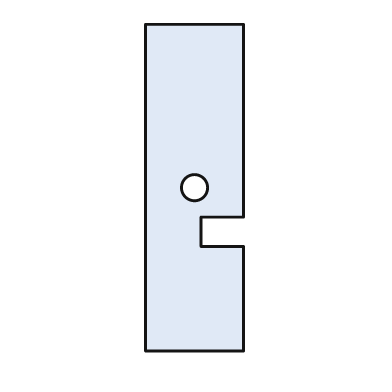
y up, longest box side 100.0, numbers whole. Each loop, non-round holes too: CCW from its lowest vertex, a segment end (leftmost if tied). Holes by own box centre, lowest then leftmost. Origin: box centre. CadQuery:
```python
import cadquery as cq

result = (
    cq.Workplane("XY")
    .moveTo(-15.0, -50.0)
    .lineTo(15.0, -50.0)
    .lineTo(15.0, -18.0)
    .lineTo(2.0, -18.0)
    .lineTo(2.0, -9.0)
    .lineTo(15.0, -9.0)
    .lineTo(15.0, 50.0)
    .lineTo(-15.0, 50.0)
    .close()
    .moveTo(0.0, 0.0)
    .circle(4.0)
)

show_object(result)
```